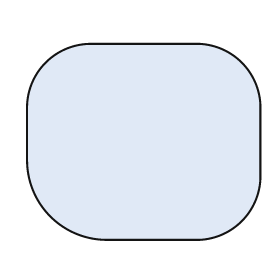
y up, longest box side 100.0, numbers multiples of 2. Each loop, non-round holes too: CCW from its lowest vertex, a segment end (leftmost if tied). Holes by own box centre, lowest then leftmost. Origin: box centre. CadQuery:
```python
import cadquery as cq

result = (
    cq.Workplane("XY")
    .moveTo(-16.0, -42.0)
    .lineTo(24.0, -42.0)
    .threePointArc((42.0, -34.0), (50.0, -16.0))
    .lineTo(50.0, 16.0)
    .threePointArc((42.0, 34.0), (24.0, 42.0))
    .lineTo(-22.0, 42.0)
    .threePointArc((-42.0, 34.0), (-50.0, 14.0))
    .lineTo(-50.0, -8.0)
    .threePointArc((-40.0, -32.0), (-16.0, -42.0))
    .close()
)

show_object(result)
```